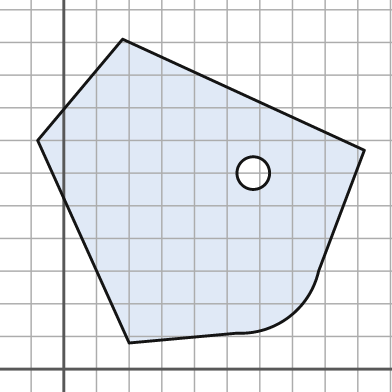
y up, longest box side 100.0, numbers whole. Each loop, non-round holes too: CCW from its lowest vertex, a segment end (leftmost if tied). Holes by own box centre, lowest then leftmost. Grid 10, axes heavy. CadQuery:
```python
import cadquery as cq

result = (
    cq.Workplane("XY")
    .moveTo(20.0, 8.0)
    .lineTo(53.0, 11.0)
    .threePointArc((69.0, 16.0), (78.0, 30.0))
    .lineTo(92.0, 67.0)
    .lineTo(18.0, 101.0)
    .lineTo(-8.0, 70.0)
    .close()
    .moveTo(58.0, 60.0)
    .circle(5.0)
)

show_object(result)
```